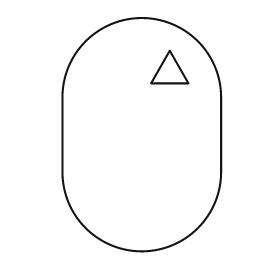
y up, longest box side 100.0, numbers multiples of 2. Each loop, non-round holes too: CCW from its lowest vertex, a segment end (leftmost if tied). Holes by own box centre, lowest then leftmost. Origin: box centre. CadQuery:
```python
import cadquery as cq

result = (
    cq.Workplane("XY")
    .moveTo(-34.0, -16.0)
    .threePointArc((0.0, -50.0), (34.0, -16.0))
    .lineTo(34.0, 16.0)
    .threePointArc((0.0, 50.0), (-34.0, 16.0))
    .close()
    .moveTo(4.0, 22.0)
    .lineTo(20.0, 22.0)
    .lineTo(12.0, 36.0)
    .close()
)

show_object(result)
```